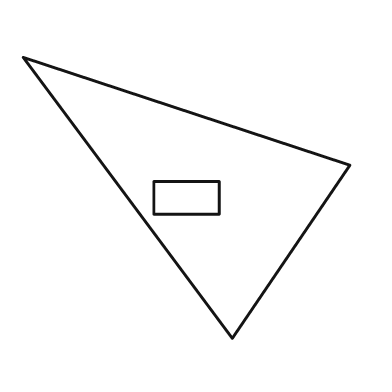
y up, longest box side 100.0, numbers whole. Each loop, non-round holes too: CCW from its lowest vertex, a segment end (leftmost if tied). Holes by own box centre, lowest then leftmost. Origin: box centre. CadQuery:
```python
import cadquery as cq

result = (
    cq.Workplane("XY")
    .moveTo(14.0, -43.0)
    .lineTo(50.0, 10.0)
    .lineTo(-50.0, 43.0)
    .close()
    .moveTo(-10.0, -5.0)
    .lineTo(10.0, -5.0)
    .lineTo(10.0, 5.0)
    .lineTo(-10.0, 5.0)
    .close()
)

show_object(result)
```